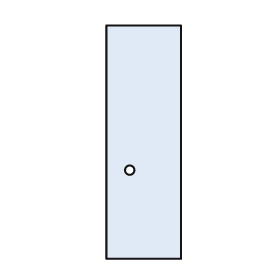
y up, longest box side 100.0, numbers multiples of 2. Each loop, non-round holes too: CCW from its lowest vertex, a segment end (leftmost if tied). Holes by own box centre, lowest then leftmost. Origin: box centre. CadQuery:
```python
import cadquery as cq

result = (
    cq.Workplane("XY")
    .moveTo(-16.0, -50.0)
    .lineTo(16.0, -50.0)
    .lineTo(16.0, 50.0)
    .lineTo(-16.0, 50.0)
    .close()
    .moveTo(-6.0, -12.0)
    .circle(2.0)
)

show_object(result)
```